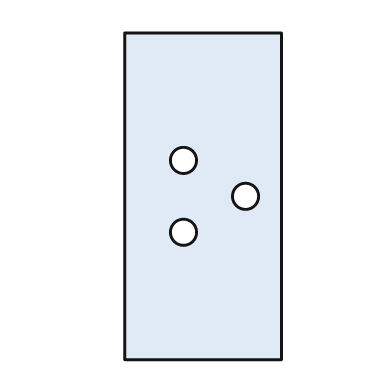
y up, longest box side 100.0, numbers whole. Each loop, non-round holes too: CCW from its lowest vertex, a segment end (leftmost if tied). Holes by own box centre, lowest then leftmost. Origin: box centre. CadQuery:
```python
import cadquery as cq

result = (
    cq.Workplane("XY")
    .moveTo(-24.0, -50.0)
    .lineTo(24.0, -50.0)
    .lineTo(24.0, 50.0)
    .lineTo(-24.0, 50.0)
    .close()
    .moveTo(-6.0, -11.0)
    .circle(4.0)
    .moveTo(13.0, 0.0)
    .circle(4.0)
    .moveTo(-6.0, 11.0)
    .circle(4.0)
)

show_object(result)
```